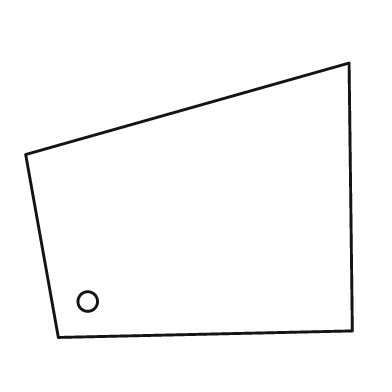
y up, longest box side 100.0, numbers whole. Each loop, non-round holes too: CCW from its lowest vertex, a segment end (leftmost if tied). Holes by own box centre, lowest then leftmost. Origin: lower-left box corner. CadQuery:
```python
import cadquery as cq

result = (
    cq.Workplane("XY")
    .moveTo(10.0, 0.0)
    .lineTo(100.0, 2.0)
    .lineTo(99.0, 84.0)
    .lineTo(0.0, 56.0)
    .close()
    .moveTo(19.0, 11.0)
    .circle(3.0)
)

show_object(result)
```